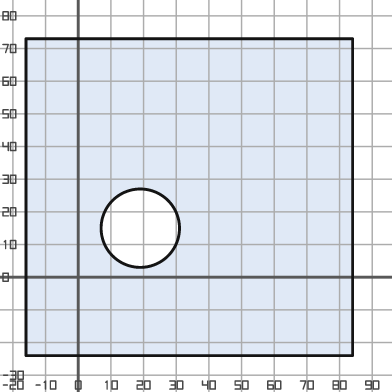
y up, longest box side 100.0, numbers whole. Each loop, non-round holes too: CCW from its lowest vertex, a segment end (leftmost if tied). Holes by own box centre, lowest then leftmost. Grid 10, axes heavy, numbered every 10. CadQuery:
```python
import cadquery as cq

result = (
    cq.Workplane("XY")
    .moveTo(-16.0, -24.0)
    .lineTo(84.0, -24.0)
    .lineTo(84.0, 73.0)
    .lineTo(-16.0, 73.0)
    .close()
    .moveTo(19.0, 15.0)
    .circle(12.0)
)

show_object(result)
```